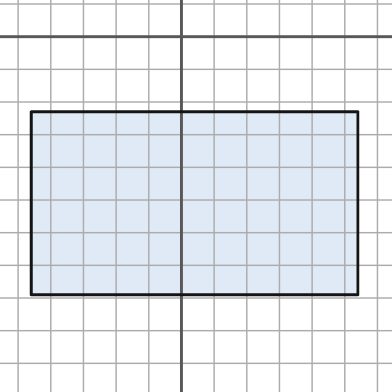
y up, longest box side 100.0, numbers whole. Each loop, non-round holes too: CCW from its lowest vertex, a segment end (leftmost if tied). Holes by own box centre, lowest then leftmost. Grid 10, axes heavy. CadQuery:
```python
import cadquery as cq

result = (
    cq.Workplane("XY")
    .moveTo(-46.0, -79.0)
    .lineTo(54.0, -79.0)
    .lineTo(54.0, -23.0)
    .lineTo(-46.0, -23.0)
    .close()
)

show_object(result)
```